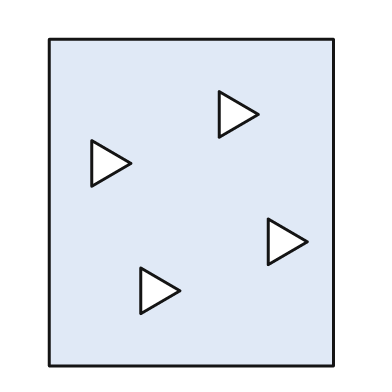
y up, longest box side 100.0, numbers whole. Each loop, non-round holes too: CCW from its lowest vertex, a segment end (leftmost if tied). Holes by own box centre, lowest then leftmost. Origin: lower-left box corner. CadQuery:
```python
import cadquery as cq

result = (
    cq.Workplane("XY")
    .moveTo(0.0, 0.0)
    .lineTo(87.0, 0.0)
    .lineTo(87.0, 100.0)
    .lineTo(0.0, 100.0)
    .close()
    .moveTo(28.0, 16.0)
    .lineTo(40.0, 23.0)
    .lineTo(28.0, 30.0)
    .close()
    .moveTo(67.0, 31.0)
    .lineTo(79.0, 38.0)
    .lineTo(67.0, 45.0)
    .close()
    .moveTo(13.0, 55.0)
    .lineTo(25.0, 62.0)
    .lineTo(13.0, 69.0)
    .close()
    .moveTo(52.0, 70.0)
    .lineTo(64.0, 77.0)
    .lineTo(52.0, 84.0)
    .close()
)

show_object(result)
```